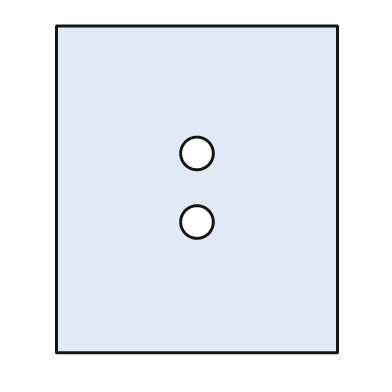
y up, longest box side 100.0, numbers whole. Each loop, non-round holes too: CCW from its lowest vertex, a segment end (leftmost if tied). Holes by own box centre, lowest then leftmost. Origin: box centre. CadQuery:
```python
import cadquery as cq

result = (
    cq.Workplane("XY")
    .moveTo(-43.0, -50.0)
    .lineTo(43.0, -50.0)
    .lineTo(43.0, 50.0)
    .lineTo(-43.0, 50.0)
    .close()
    .moveTo(0.0, -10.0)
    .circle(5.0)
    .moveTo(0.0, 11.0)
    .circle(5.0)
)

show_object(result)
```